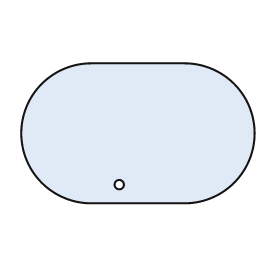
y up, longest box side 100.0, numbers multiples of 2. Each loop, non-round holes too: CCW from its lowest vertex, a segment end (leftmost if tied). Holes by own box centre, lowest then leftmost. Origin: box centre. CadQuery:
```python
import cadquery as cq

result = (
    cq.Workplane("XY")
    .moveTo(-20.0, -30.0)
    .lineTo(20.0, -30.0)
    .threePointArc((50.0, 0.0), (20.0, 30.0))
    .lineTo(-20.0, 30.0)
    .threePointArc((-50.0, 0.0), (-20.0, -30.0))
    .close()
    .moveTo(-8.0, -22.0)
    .circle(2.0)
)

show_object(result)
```